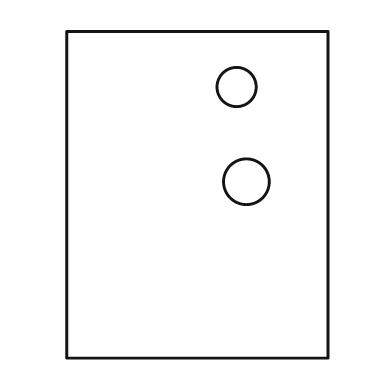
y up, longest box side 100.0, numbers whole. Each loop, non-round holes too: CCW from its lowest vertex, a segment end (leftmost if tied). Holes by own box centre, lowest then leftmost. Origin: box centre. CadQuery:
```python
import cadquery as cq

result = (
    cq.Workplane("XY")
    .moveTo(-40.0, -50.0)
    .lineTo(40.0, -50.0)
    .lineTo(40.0, 50.0)
    .lineTo(-40.0, 50.0)
    .close()
    .moveTo(15.0, 4.0)
    .circle(7.0)
    .moveTo(12.0, 33.0)
    .circle(6.0)
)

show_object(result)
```